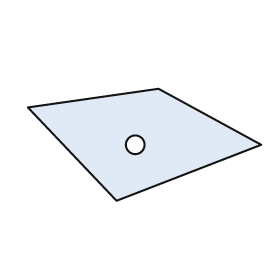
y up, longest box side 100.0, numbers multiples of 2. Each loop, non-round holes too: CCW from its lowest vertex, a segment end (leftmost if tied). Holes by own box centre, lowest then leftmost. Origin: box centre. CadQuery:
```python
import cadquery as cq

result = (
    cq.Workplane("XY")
    .moveTo(-12.0, -24.0)
    .lineTo(50.0, 0.0)
    .lineTo(6.0, 24.0)
    .lineTo(-50.0, 16.0)
    .close()
    .moveTo(-4.0, 0.0)
    .circle(4.0)
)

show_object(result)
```